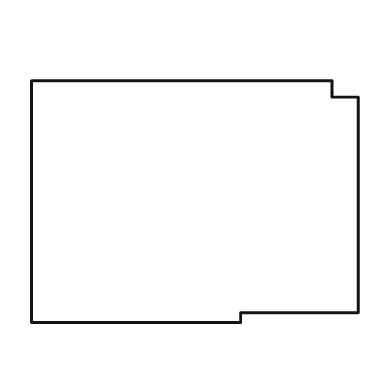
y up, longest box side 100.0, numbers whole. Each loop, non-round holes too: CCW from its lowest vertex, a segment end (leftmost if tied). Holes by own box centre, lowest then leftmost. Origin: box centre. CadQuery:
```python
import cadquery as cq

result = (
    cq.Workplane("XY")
    .moveTo(-50.0, -37.0)
    .lineTo(14.0, -37.0)
    .lineTo(14.0, -34.0)
    .lineTo(50.0, -34.0)
    .lineTo(50.0, 32.0)
    .lineTo(42.0, 32.0)
    .lineTo(42.0, 37.0)
    .lineTo(-50.0, 37.0)
    .close()
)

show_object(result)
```